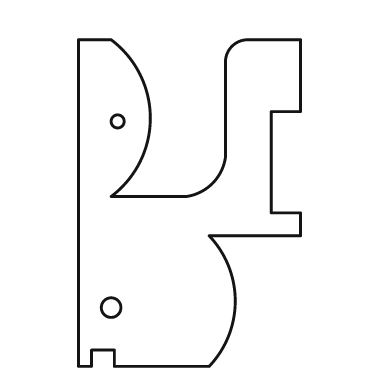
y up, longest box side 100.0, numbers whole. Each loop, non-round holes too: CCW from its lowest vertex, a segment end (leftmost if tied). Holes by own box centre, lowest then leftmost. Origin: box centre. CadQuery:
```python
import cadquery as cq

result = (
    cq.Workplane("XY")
    .moveTo(-34.0, -50.0)
    .lineTo(-30.0, -50.0)
    .lineTo(-30.0, -45.0)
    .lineTo(-23.0, -45.0)
    .lineTo(-23.0, -50.0)
    .lineTo(6.0, -50.0)
    .threePointArc((14.0, -30.0), (6.0, -10.0))
    .lineTo(34.0, -10.0)
    .lineTo(34.0, -3.0)
    .lineTo(25.0, -3.0)
    .lineTo(25.0, 28.0)
    .lineTo(34.0, 28.0)
    .lineTo(34.0, 50.0)
    .lineTo(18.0, 50.0)
    .threePointArc((13.0, 48.0), (11.0, 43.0))
    .lineTo(11.0, 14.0)
    .threePointArc((7.0, 6.0), (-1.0, 2.0))
    .lineTo(-24.0, 2.0)
    .threePointArc((-12.0, 26.0), (-24.0, 50.0))
    .lineTo(-34.0, 50.0)
    .close()
    .moveTo(-24.0, -32.0)
    .circle(3.0)
    .moveTo(-22.0, 25.0)
    .circle(2.0)
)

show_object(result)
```